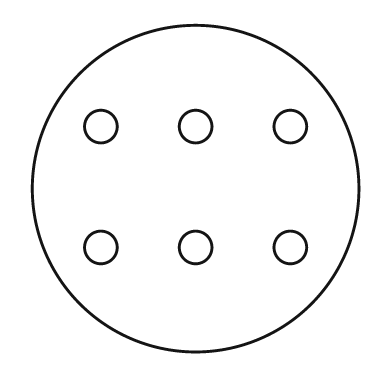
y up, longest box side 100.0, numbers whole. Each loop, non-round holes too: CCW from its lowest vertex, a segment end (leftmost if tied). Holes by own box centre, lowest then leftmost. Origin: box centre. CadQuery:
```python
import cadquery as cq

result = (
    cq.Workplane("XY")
    .moveTo(0.0, 0.0)
    .circle(50.0)
    .moveTo(-29.0, -18.0)
    .circle(5.0)
    .moveTo(0.0, -18.0)
    .circle(5.0)
    .moveTo(29.0, -18.0)
    .circle(5.0)
    .moveTo(-29.0, 19.0)
    .circle(5.0)
    .moveTo(0.0, 19.0)
    .circle(5.0)
    .moveTo(29.0, 19.0)
    .circle(5.0)
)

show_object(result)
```